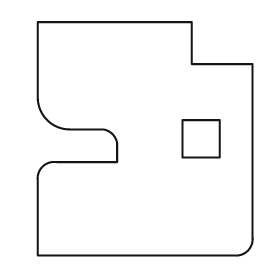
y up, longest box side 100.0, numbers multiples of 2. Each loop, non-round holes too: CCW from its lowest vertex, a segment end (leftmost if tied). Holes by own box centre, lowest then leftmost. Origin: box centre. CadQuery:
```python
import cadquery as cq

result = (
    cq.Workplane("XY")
    .moveTo(-46.0, -50.0)
    .lineTo(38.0, -50.0)
    .threePointArc((44.0, -48.0), (46.0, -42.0))
    .lineTo(46.0, 32.0)
    .lineTo(20.0, 32.0)
    .lineTo(20.0, 50.0)
    .lineTo(-46.0, 50.0)
    .lineTo(-46.0, 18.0)
    .threePointArc((-42.0, 8.0), (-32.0, 4.0))
    .lineTo(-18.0, 4.0)
    .threePointArc((-14.0, 2.0), (-12.0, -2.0))
    .lineTo(-12.0, -10.0)
    .lineTo(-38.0, -10.0)
    .threePointArc((-44.0, -12.0), (-46.0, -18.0))
    .close()
    .moveTo(16.0, -8.0)
    .lineTo(32.0, -8.0)
    .lineTo(32.0, 8.0)
    .lineTo(16.0, 8.0)
    .close()
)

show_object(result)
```